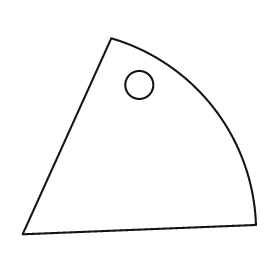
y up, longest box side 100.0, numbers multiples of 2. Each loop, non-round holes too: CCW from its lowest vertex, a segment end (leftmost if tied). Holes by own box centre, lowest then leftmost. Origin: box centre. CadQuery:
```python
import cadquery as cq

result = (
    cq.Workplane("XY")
    .moveTo(-50.0, -42.0)
    .lineTo(50.0, -38.0)
    .threePointArc((32.0, 12.0), (-12.0, 42.0))
    .close()
    .moveTo(0.0, 22.0)
    .circle(6.0)
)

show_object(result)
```